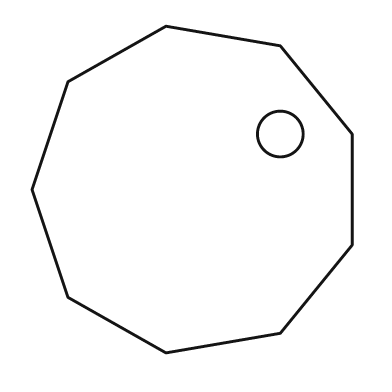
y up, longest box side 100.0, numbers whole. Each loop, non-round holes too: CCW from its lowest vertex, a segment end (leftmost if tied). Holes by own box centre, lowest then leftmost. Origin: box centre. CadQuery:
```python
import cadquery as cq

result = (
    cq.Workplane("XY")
    .moveTo(-8.0, -50.0)
    .lineTo(27.0, -44.0)
    .lineTo(49.0, -17.0)
    .lineTo(49.0, 17.0)
    .lineTo(27.0, 44.0)
    .lineTo(-8.0, 50.0)
    .lineTo(-38.0, 33.0)
    .lineTo(-49.0, 0.0)
    .lineTo(-38.0, -33.0)
    .close()
    .moveTo(27.0, 17.0)
    .circle(7.0)
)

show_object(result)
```